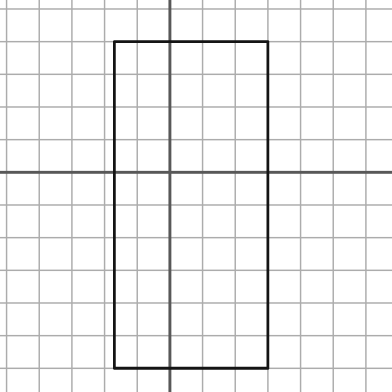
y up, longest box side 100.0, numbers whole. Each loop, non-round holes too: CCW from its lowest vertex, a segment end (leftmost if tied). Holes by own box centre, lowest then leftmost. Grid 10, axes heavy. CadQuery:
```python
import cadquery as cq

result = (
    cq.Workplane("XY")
    .moveTo(-17.0, -60.0)
    .lineTo(30.0, -60.0)
    .lineTo(30.0, 40.0)
    .lineTo(-17.0, 40.0)
    .close()
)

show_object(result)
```